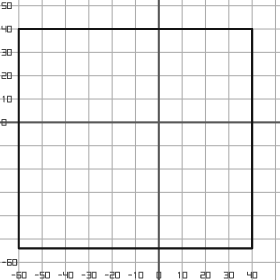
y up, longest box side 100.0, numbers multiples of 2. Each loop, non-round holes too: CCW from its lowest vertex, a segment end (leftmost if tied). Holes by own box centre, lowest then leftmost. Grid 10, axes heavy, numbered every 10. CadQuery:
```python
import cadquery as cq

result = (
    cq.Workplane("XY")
    .moveTo(-60.0, -54.0)
    .lineTo(40.0, -54.0)
    .lineTo(40.0, 40.0)
    .lineTo(-60.0, 40.0)
    .close()
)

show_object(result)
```